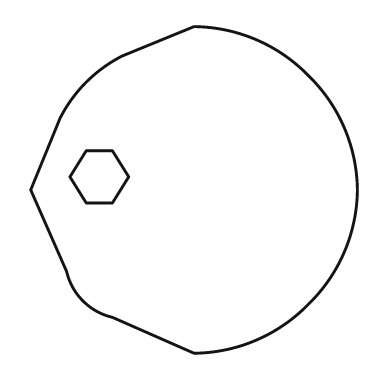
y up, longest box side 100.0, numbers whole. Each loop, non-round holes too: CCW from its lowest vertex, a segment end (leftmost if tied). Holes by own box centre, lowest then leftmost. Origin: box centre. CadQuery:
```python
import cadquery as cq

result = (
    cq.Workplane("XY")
    .moveTo(0.0, -50.0)
    .threePointArc((19.0, -46.0), (35.0, -35.0))
    .threePointArc((46.0, -19.0), (50.0, 0.0))
    .threePointArc((46.0, 19.0), (35.0, 35.0))
    .threePointArc((19.0, 46.0), (0.0, 50.0))
    .lineTo(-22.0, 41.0)
    .threePointArc((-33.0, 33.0), (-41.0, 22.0))
    .lineTo(-50.0, 0.0)
    .lineTo(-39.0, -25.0)
    .threePointArc((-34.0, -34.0), (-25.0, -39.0))
    .close()
    .moveTo(-33.0, -4.0)
    .lineTo(-25.0, -4.0)
    .lineTo(-20.0, 4.0)
    .lineTo(-25.0, 12.0)
    .lineTo(-33.0, 12.0)
    .lineTo(-38.0, 4.0)
    .close()
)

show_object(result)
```